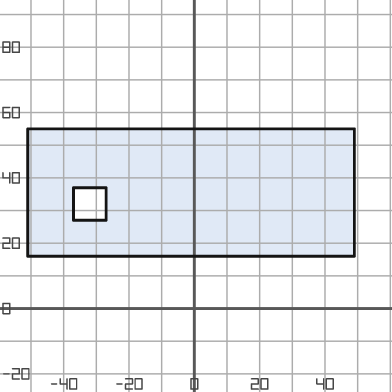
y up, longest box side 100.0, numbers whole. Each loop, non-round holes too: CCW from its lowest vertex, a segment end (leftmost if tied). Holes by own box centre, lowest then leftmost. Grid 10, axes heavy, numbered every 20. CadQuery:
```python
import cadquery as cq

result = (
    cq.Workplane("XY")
    .moveTo(-51.0, 16.0)
    .lineTo(49.0, 16.0)
    .lineTo(49.0, 55.0)
    .lineTo(-51.0, 55.0)
    .close()
    .moveTo(-37.0, 27.0)
    .lineTo(-27.0, 27.0)
    .lineTo(-27.0, 37.0)
    .lineTo(-37.0, 37.0)
    .close()
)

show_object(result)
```